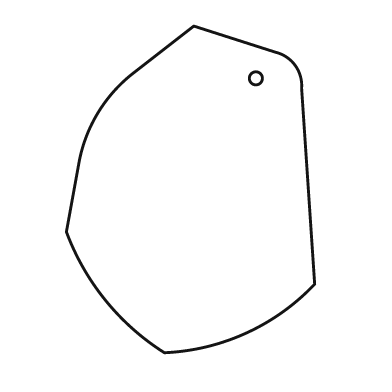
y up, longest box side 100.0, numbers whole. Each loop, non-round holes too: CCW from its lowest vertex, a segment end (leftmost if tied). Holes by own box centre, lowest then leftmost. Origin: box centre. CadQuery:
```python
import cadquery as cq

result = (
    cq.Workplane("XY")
    .moveTo(-8.0, -50.0)
    .threePointArc((17.0, -44.0), (38.0, -29.0))
    .lineTo(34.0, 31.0)
    .threePointArc((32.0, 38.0), (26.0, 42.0))
    .lineTo(1.0, 50.0)
    .lineTo(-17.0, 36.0)
    .threePointArc((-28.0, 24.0), (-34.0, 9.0))
    .lineTo(-38.0, -13.0)
    .threePointArc((-26.0, -34.0), (-8.0, -50.0))
    .close()
    .moveTo(20.0, 34.0)
    .circle(2.0)
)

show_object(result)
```